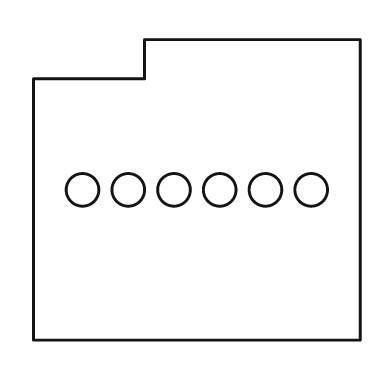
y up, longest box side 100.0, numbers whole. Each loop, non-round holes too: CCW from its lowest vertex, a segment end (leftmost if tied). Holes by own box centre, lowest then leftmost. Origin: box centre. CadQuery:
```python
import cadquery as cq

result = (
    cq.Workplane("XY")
    .moveTo(-50.0, -46.0)
    .lineTo(50.0, -46.0)
    .lineTo(50.0, 46.0)
    .lineTo(-16.0, 46.0)
    .lineTo(-16.0, 34.0)
    .lineTo(-50.0, 34.0)
    .close()
    .moveTo(-35.0, 0.0)
    .circle(5.0)
    .moveTo(-21.0, 0.0)
    .circle(5.0)
    .moveTo(-7.0, 0.0)
    .circle(5.0)
    .moveTo(7.0, 0.0)
    .circle(5.0)
    .moveTo(21.0, 0.0)
    .circle(5.0)
    .moveTo(35.0, 0.0)
    .circle(5.0)
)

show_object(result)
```